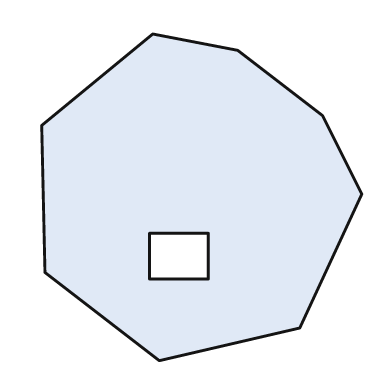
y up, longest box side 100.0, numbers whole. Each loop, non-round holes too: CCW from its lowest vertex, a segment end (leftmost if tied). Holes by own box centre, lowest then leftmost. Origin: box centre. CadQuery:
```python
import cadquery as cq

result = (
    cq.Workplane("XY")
    .moveTo(-13.0, -50.0)
    .lineTo(30.0, -40.0)
    .lineTo(49.0, 1.0)
    .lineTo(37.0, 25.0)
    .lineTo(11.0, 45.0)
    .lineTo(-15.0, 50.0)
    .lineTo(-49.0, 22.0)
    .lineTo(-48.0, -23.0)
    .close()
    .moveTo(-16.0, -25.0)
    .lineTo(2.0, -25.0)
    .lineTo(2.0, -11.0)
    .lineTo(-16.0, -11.0)
    .close()
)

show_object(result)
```